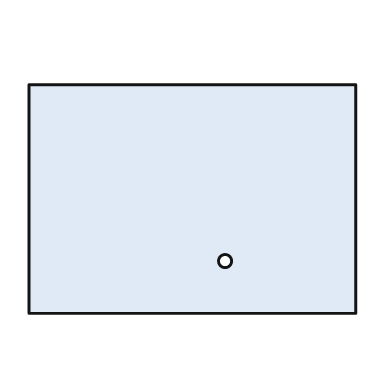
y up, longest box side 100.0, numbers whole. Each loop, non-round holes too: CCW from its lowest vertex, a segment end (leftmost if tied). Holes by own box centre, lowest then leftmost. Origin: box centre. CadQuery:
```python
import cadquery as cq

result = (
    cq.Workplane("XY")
    .moveTo(-50.0, -35.0)
    .lineTo(50.0, -35.0)
    .lineTo(50.0, 35.0)
    .lineTo(-50.0, 35.0)
    .close()
    .moveTo(10.0, -19.0)
    .circle(2.0)
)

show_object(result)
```